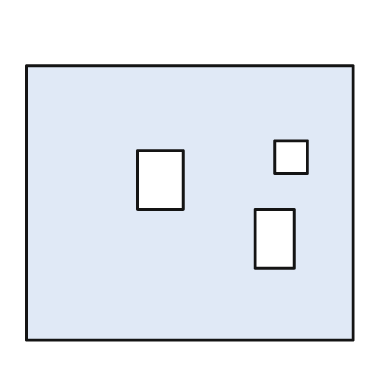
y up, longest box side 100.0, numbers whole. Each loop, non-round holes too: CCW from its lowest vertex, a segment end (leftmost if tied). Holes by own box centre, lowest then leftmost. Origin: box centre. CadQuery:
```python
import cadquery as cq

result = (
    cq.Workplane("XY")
    .moveTo(-50.0, -42.0)
    .lineTo(50.0, -42.0)
    .lineTo(50.0, 42.0)
    .lineTo(-50.0, 42.0)
    .close()
    .moveTo(20.0, -20.0)
    .lineTo(32.0, -20.0)
    .lineTo(32.0, -2.0)
    .lineTo(20.0, -2.0)
    .close()
    .moveTo(-16.0, -2.0)
    .lineTo(-2.0, -2.0)
    .lineTo(-2.0, 16.0)
    .lineTo(-16.0, 16.0)
    .close()
    .moveTo(26.0, 9.0)
    .lineTo(36.0, 9.0)
    .lineTo(36.0, 19.0)
    .lineTo(26.0, 19.0)
    .close()
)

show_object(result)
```